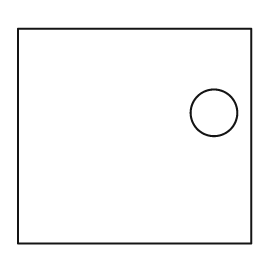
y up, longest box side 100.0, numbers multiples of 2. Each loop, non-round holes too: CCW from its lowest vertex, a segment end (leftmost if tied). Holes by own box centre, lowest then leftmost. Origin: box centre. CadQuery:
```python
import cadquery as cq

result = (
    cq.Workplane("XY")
    .moveTo(-50.0, -46.0)
    .lineTo(50.0, -46.0)
    .lineTo(50.0, 46.0)
    .lineTo(-50.0, 46.0)
    .close()
    .moveTo(34.0, 10.0)
    .circle(10.0)
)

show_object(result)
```